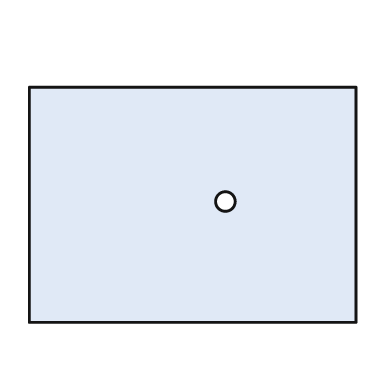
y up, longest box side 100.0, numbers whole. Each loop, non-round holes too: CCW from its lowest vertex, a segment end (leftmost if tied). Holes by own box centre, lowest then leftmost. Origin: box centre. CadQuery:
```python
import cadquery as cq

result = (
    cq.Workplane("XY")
    .moveTo(-50.0, -36.0)
    .lineTo(50.0, -36.0)
    .lineTo(50.0, 36.0)
    .lineTo(-50.0, 36.0)
    .close()
    .moveTo(10.0, 1.0)
    .circle(3.0)
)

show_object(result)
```